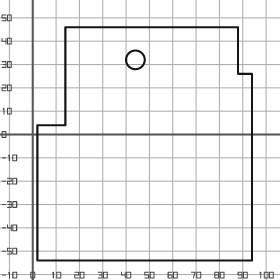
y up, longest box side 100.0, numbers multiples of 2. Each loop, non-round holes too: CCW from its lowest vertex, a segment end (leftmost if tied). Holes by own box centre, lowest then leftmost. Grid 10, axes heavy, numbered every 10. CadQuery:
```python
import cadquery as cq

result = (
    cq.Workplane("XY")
    .moveTo(2.0, -54.0)
    .lineTo(94.0, -54.0)
    .lineTo(94.0, 26.0)
    .lineTo(88.0, 26.0)
    .lineTo(88.0, 46.0)
    .lineTo(14.0, 46.0)
    .lineTo(14.0, 4.0)
    .lineTo(2.0, 4.0)
    .close()
    .moveTo(44.0, 32.0)
    .circle(4.0)
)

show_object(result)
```